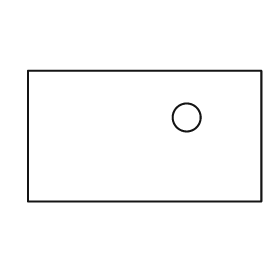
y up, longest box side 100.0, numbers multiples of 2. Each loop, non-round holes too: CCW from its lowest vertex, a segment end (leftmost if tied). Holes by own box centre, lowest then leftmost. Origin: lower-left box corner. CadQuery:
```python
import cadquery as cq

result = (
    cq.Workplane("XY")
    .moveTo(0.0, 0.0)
    .lineTo(100.0, 0.0)
    .lineTo(100.0, 56.0)
    .lineTo(0.0, 56.0)
    .close()
    .moveTo(68.0, 36.0)
    .circle(6.0)
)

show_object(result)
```